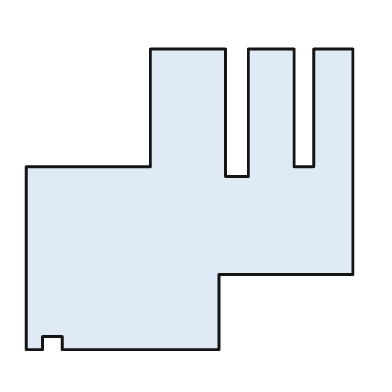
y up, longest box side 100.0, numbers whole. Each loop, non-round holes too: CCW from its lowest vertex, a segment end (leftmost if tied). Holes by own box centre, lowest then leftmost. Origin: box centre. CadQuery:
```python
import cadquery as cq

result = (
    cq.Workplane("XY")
    .moveTo(-50.0, -46.0)
    .lineTo(-45.0, -46.0)
    .lineTo(-45.0, -42.0)
    .lineTo(-39.0, -42.0)
    .lineTo(-39.0, -46.0)
    .lineTo(9.0, -46.0)
    .lineTo(9.0, -23.0)
    .lineTo(50.0, -23.0)
    .lineTo(50.0, 46.0)
    .lineTo(38.0, 46.0)
    .lineTo(38.0, 10.0)
    .lineTo(32.0, 10.0)
    .lineTo(32.0, 46.0)
    .lineTo(18.0, 46.0)
    .lineTo(18.0, 7.0)
    .lineTo(11.0, 7.0)
    .lineTo(11.0, 46.0)
    .lineTo(-12.0, 46.0)
    .lineTo(-12.0, 10.0)
    .lineTo(-50.0, 10.0)
    .close()
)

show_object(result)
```